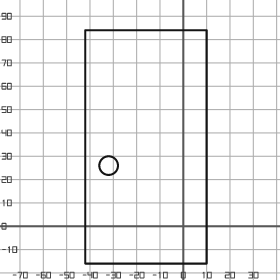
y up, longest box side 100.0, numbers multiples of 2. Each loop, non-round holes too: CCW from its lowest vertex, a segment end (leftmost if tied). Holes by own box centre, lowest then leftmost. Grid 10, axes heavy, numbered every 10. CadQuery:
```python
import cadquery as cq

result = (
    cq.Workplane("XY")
    .moveTo(-42.0, -16.0)
    .lineTo(10.0, -16.0)
    .lineTo(10.0, 84.0)
    .lineTo(-42.0, 84.0)
    .close()
    .moveTo(-32.0, 26.0)
    .circle(4.0)
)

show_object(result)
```